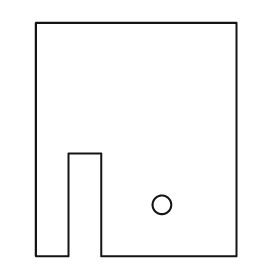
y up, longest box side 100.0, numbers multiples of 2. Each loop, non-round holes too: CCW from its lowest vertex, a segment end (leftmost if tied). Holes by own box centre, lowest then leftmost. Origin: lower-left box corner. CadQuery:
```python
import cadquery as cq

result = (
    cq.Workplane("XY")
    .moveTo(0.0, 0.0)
    .lineTo(14.0, 0.0)
    .lineTo(14.0, 44.0)
    .lineTo(28.0, 44.0)
    .lineTo(28.0, 0.0)
    .lineTo(86.0, 0.0)
    .lineTo(86.0, 100.0)
    .lineTo(0.0, 100.0)
    .close()
    .moveTo(54.0, 22.0)
    .circle(4.0)
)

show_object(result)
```